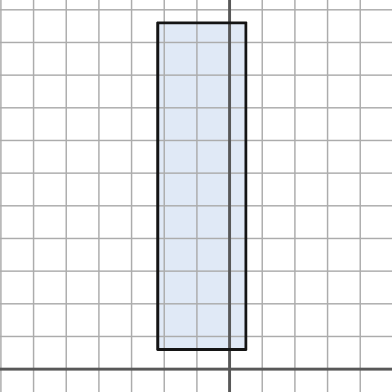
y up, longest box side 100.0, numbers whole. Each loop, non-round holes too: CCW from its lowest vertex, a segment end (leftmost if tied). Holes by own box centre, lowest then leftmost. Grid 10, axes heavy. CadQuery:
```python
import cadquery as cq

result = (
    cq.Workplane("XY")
    .moveTo(-22.0, 6.0)
    .lineTo(5.0, 6.0)
    .lineTo(5.0, 106.0)
    .lineTo(-22.0, 106.0)
    .close()
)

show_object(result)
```